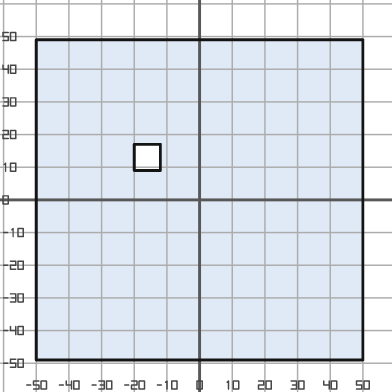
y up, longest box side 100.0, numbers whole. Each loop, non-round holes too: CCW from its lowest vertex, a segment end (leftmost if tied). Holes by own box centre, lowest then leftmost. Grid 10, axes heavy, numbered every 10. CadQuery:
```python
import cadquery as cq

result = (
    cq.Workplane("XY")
    .moveTo(-50.0, -49.0)
    .lineTo(50.0, -49.0)
    .lineTo(50.0, 49.0)
    .lineTo(-50.0, 49.0)
    .close()
    .moveTo(-20.0, 9.0)
    .lineTo(-12.0, 9.0)
    .lineTo(-12.0, 17.0)
    .lineTo(-20.0, 17.0)
    .close()
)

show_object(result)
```